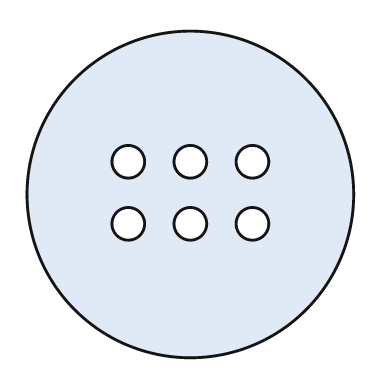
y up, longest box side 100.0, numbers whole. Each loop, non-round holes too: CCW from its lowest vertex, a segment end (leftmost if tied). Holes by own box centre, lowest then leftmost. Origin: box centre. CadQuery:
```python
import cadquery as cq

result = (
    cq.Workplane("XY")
    .moveTo(0.0, 0.0)
    .circle(50.0)
    .moveTo(-19.0, -9.0)
    .circle(5.0)
    .moveTo(0.0, -9.0)
    .circle(5.0)
    .moveTo(19.0, -9.0)
    .circle(5.0)
    .moveTo(-19.0, 10.0)
    .circle(5.0)
    .moveTo(0.0, 10.0)
    .circle(5.0)
    .moveTo(19.0, 10.0)
    .circle(5.0)
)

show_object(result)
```